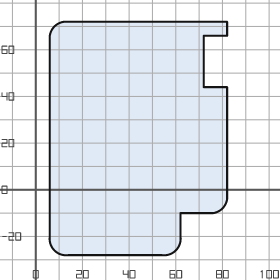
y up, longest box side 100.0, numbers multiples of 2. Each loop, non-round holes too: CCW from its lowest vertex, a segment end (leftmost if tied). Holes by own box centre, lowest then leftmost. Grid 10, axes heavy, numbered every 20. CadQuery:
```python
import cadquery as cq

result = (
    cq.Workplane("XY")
    .moveTo(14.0, -28.0)
    .lineTo(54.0, -28.0)
    .threePointArc((60.0, -26.0), (62.0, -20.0))
    .lineTo(62.0, -10.0)
    .lineTo(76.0, -10.0)
    .threePointArc((80.0, -8.0), (82.0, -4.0))
    .lineTo(82.0, 44.0)
    .lineTo(72.0, 44.0)
    .lineTo(72.0, 66.0)
    .lineTo(82.0, 66.0)
    .lineTo(82.0, 72.0)
    .lineTo(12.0, 72.0)
    .threePointArc((8.0, 70.0), (6.0, 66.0))
    .lineTo(6.0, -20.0)
    .threePointArc((8.0, -26.0), (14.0, -28.0))
    .close()
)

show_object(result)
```